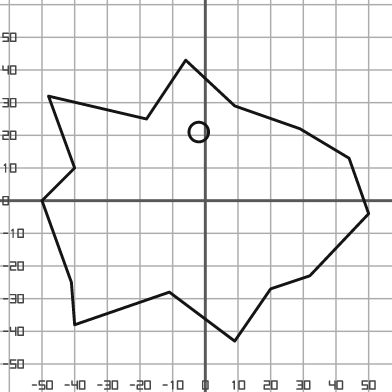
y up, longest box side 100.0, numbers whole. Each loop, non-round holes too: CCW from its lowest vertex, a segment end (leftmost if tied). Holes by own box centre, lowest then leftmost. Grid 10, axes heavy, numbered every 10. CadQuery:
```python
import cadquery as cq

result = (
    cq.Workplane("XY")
    .moveTo(9.0, -43.0)
    .lineTo(20.0, -27.0)
    .lineTo(32.0, -23.0)
    .lineTo(50.0, -4.0)
    .lineTo(44.0, 13.0)
    .lineTo(29.0, 22.0)
    .lineTo(9.0, 29.0)
    .lineTo(-6.0, 43.0)
    .lineTo(-18.0, 25.0)
    .lineTo(-48.0, 32.0)
    .lineTo(-40.0, 10.0)
    .lineTo(-50.0, 0.0)
    .lineTo(-41.0, -25.0)
    .lineTo(-40.0, -38.0)
    .lineTo(-11.0, -28.0)
    .close()
    .moveTo(-2.0, 21.0)
    .circle(3.0)
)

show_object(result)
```